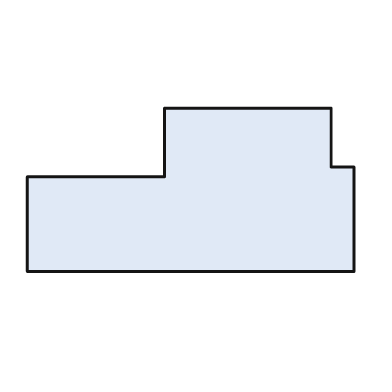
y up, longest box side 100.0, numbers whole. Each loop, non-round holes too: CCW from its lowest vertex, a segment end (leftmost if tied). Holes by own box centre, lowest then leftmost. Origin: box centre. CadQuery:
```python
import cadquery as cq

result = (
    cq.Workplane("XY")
    .moveTo(-50.0, -25.0)
    .lineTo(50.0, -25.0)
    .lineTo(50.0, 7.0)
    .lineTo(43.0, 7.0)
    .lineTo(43.0, 25.0)
    .lineTo(-8.0, 25.0)
    .lineTo(-8.0, 4.0)
    .lineTo(-50.0, 4.0)
    .close()
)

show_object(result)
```